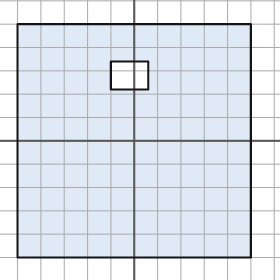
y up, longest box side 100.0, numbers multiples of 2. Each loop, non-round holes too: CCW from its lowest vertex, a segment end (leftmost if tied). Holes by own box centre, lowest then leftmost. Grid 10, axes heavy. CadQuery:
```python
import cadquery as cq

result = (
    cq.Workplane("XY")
    .moveTo(-50.0, -50.0)
    .lineTo(50.0, -50.0)
    .lineTo(50.0, 50.0)
    .lineTo(-50.0, 50.0)
    .close()
    .moveTo(-10.0, 22.0)
    .lineTo(6.0, 22.0)
    .lineTo(6.0, 34.0)
    .lineTo(-10.0, 34.0)
    .close()
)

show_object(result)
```